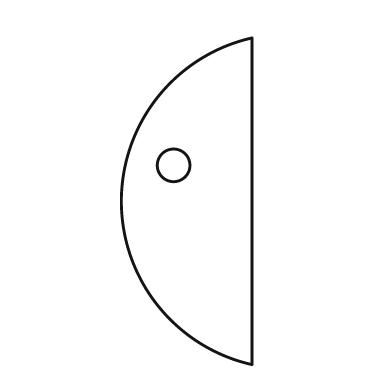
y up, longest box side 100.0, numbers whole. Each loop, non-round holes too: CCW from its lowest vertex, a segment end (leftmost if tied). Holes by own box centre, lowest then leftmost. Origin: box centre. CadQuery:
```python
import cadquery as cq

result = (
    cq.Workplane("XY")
    .moveTo(20.0, -50.0)
    .lineTo(20.0, 50.0)
    .threePointArc((-20.0, 0.0), (20.0, -50.0))
    .close()
    .moveTo(-4.0, 11.0)
    .circle(5.0)
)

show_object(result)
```